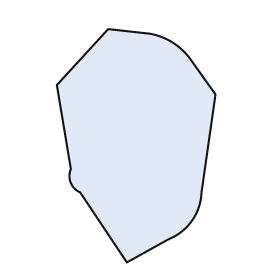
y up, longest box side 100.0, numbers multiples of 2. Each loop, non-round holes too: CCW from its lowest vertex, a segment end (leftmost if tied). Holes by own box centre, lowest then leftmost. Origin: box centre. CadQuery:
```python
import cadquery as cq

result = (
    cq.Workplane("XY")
    .moveTo(-4.0, -50.0)
    .lineTo(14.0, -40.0)
    .threePointArc((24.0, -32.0), (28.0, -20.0))
    .lineTo(34.0, 22.0)
    .lineTo(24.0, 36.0)
    .threePointArc((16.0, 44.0), (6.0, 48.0))
    .lineTo(-12.0, 50.0)
    .lineTo(-34.0, 26.0)
    .lineTo(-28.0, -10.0)
    .threePointArc((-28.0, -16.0), (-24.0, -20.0))
    .close()
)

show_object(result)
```